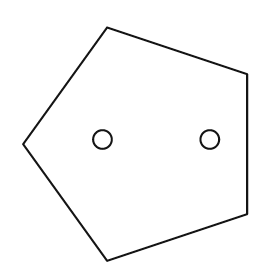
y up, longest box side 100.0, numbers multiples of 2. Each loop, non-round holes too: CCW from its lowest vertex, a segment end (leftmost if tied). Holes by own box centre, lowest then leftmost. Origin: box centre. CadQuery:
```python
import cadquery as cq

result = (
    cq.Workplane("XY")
    .moveTo(-12.0, -50.0)
    .lineTo(48.0, -30.0)
    .lineTo(48.0, 30.0)
    .lineTo(-12.0, 50.0)
    .lineTo(-48.0, 0.0)
    .close()
    .moveTo(-14.0, 2.0)
    .circle(4.0)
    .moveTo(32.0, 2.0)
    .circle(4.0)
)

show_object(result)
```